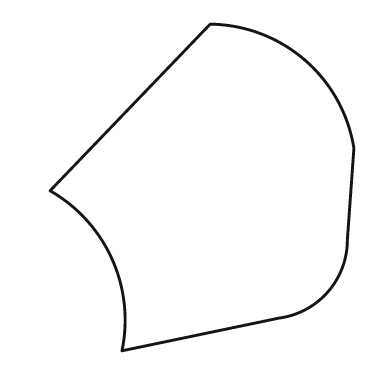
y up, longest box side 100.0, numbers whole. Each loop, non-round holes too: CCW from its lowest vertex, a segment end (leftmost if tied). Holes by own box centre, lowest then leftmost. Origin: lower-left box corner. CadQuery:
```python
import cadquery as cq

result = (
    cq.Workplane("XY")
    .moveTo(22.0, 0.0)
    .lineTo(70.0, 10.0)
    .threePointArc((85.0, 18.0), (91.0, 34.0))
    .lineTo(93.0, 62.0)
    .threePointArc((78.0, 89.0), (49.0, 100.0))
    .lineTo(0.0, 49.0)
    .threePointArc((19.0, 28.0), (22.0, 0.0))
    .close()
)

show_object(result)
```